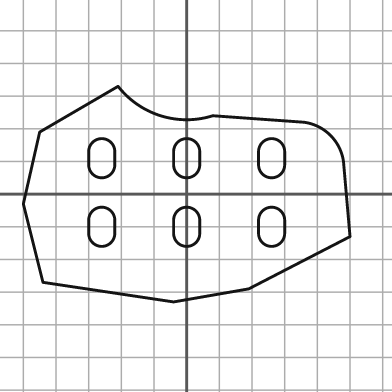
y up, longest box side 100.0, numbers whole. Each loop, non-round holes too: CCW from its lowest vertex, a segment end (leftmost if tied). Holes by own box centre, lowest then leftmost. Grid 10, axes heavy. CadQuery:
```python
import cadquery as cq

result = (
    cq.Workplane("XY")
    .moveTo(-4.0, -33.0)
    .lineTo(19.0, -29.0)
    .lineTo(50.0, -13.0)
    .lineTo(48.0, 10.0)
    .threePointArc((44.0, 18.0), (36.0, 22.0))
    .lineTo(8.0, 24.0)
    .threePointArc((-8.0, 24.0), (-21.0, 33.0))
    .lineTo(-45.0, 19.0)
    .lineTo(-50.0, -3.0)
    .lineTo(-44.0, -27.0)
    .close()
    .moveTo(-30.0, -12.0)
    .threePointArc((-26.0, -16.0), (-22.0, -12.0))
    .lineTo(-22.0, -8.0)
    .threePointArc((-26.0, -4.0), (-30.0, -8.0))
    .close()
    .moveTo(-4.0, -12.0)
    .threePointArc((0.0, -16.0), (4.0, -12.0))
    .lineTo(4.0, -8.0)
    .threePointArc((0.0, -4.0), (-4.0, -8.0))
    .close()
    .moveTo(22.0, -12.0)
    .threePointArc((26.0, -16.0), (30.0, -12.0))
    .lineTo(30.0, -8.0)
    .threePointArc((26.0, -4.0), (22.0, -8.0))
    .close()
    .moveTo(-30.0, 9.0)
    .threePointArc((-26.0, 5.0), (-22.0, 9.0))
    .lineTo(-22.0, 13.0)
    .threePointArc((-26.0, 17.0), (-30.0, 13.0))
    .close()
    .moveTo(-4.0, 9.0)
    .threePointArc((0.0, 5.0), (4.0, 9.0))
    .lineTo(4.0, 13.0)
    .threePointArc((0.0, 17.0), (-4.0, 13.0))
    .close()
    .moveTo(22.0, 9.0)
    .threePointArc((26.0, 5.0), (30.0, 9.0))
    .lineTo(30.0, 13.0)
    .threePointArc((26.0, 17.0), (22.0, 13.0))
    .close()
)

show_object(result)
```